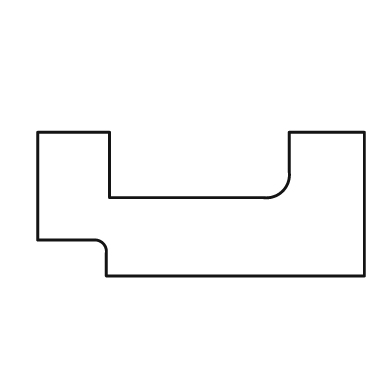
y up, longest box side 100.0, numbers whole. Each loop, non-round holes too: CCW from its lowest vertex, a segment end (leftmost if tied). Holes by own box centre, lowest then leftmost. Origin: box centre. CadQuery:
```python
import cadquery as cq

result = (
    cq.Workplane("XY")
    .moveTo(-29.0, -22.0)
    .lineTo(50.0, -22.0)
    .lineTo(50.0, 22.0)
    .lineTo(27.0, 22.0)
    .lineTo(27.0, 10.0)
    .threePointArc((25.0, 4.0), (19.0, 2.0))
    .lineTo(-28.0, 2.0)
    .lineTo(-28.0, 22.0)
    .lineTo(-50.0, 22.0)
    .lineTo(-50.0, -11.0)
    .lineTo(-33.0, -11.0)
    .threePointArc((-30.0, -12.0), (-29.0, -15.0))
    .close()
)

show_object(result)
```